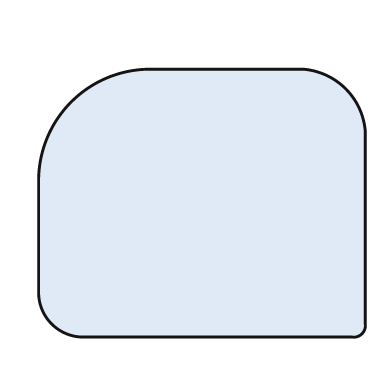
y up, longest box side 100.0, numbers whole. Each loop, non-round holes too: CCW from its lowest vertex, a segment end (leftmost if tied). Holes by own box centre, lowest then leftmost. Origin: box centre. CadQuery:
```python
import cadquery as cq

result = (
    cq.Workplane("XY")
    .moveTo(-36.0, -41.0)
    .lineTo(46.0, -41.0)
    .threePointArc((49.0, -40.0), (50.0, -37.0))
    .lineTo(50.0, 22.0)
    .threePointArc((44.0, 35.0), (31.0, 41.0))
    .lineTo(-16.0, 41.0)
    .threePointArc((-40.0, 31.0), (-50.0, 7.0))
    .lineTo(-50.0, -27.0)
    .threePointArc((-46.0, -37.0), (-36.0, -41.0))
    .close()
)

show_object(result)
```